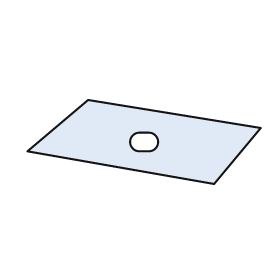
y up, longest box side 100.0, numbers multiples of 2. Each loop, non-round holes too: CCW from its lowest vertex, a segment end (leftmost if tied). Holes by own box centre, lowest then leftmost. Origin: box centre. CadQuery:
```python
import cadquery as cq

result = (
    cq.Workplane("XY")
    .moveTo(30.0, -18.0)
    .lineTo(50.0, 6.0)
    .lineTo(-24.0, 18.0)
    .lineTo(-50.0, -4.0)
    .close()
    .moveTo(-2.0, -4.0)
    .lineTo(2.0, -4.0)
    .threePointArc((6.0, 0.0), (2.0, 4.0))
    .lineTo(-2.0, 4.0)
    .threePointArc((-6.0, 0.0), (-2.0, -4.0))
    .close()
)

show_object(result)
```